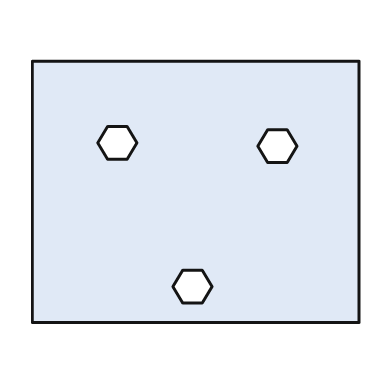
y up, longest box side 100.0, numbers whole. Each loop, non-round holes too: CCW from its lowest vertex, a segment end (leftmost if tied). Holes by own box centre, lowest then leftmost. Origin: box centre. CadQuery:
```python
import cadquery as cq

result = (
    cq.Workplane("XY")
    .moveTo(-50.0, -40.0)
    .lineTo(50.0, -40.0)
    .lineTo(50.0, 40.0)
    .lineTo(-50.0, 40.0)
    .close()
    .moveTo(-4.0, -34.0)
    .lineTo(2.0, -34.0)
    .lineTo(5.0, -29.0)
    .lineTo(2.0, -24.0)
    .lineTo(-4.0, -24.0)
    .lineTo(-7.0, -29.0)
    .close()
    .moveTo(22.0, 9.0)
    .lineTo(28.0, 9.0)
    .lineTo(31.0, 14.0)
    .lineTo(28.0, 19.0)
    .lineTo(22.0, 19.0)
    .lineTo(19.0, 14.0)
    .close()
    .moveTo(-27.0, 10.0)
    .lineTo(-21.0, 10.0)
    .lineTo(-18.0, 15.0)
    .lineTo(-21.0, 20.0)
    .lineTo(-27.0, 20.0)
    .lineTo(-30.0, 15.0)
    .close()
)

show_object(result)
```